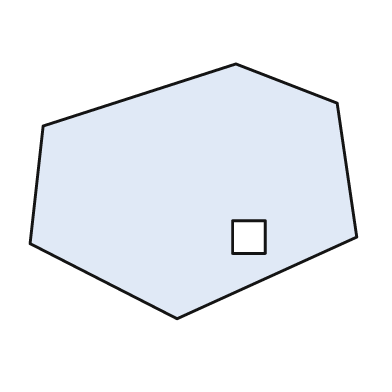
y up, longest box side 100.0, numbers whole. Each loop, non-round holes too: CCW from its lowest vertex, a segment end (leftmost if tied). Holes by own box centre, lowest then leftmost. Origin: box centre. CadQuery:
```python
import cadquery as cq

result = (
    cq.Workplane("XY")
    .moveTo(-5.0, -39.0)
    .lineTo(50.0, -14.0)
    .lineTo(44.0, 27.0)
    .lineTo(13.0, 39.0)
    .lineTo(-46.0, 20.0)
    .lineTo(-50.0, -16.0)
    .close()
    .moveTo(12.0, -19.0)
    .lineTo(22.0, -19.0)
    .lineTo(22.0, -9.0)
    .lineTo(12.0, -9.0)
    .close()
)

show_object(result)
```